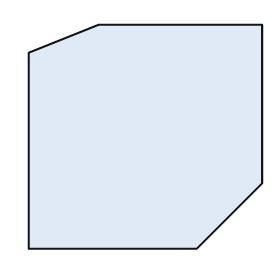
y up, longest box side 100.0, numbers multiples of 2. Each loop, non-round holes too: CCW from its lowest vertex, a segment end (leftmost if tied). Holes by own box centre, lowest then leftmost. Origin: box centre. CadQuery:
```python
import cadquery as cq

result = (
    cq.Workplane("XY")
    .moveTo(-50.0, -48.0)
    .lineTo(22.0, -48.0)
    .lineTo(50.0, -20.0)
    .lineTo(50.0, 48.0)
    .lineTo(-20.0, 48.0)
    .lineTo(-50.0, 36.0)
    .close()
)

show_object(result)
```